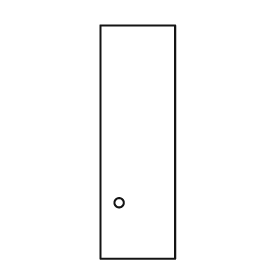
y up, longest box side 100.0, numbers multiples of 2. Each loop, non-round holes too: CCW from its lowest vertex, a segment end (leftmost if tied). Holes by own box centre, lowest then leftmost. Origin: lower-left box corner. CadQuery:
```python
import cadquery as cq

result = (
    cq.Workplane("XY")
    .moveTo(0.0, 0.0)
    .lineTo(32.0, 0.0)
    .lineTo(32.0, 100.0)
    .lineTo(0.0, 100.0)
    .close()
    .moveTo(8.0, 24.0)
    .circle(2.0)
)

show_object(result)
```